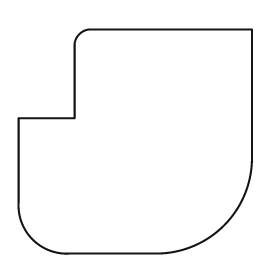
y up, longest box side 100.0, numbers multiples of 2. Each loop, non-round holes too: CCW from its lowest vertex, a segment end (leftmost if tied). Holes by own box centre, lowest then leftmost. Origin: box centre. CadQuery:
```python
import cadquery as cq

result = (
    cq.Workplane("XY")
    .moveTo(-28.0, -48.0)
    .lineTo(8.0, -48.0)
    .threePointArc((38.0, -36.0), (50.0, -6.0))
    .lineTo(50.0, 48.0)
    .lineTo(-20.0, 48.0)
    .threePointArc((-24.0, 46.0), (-26.0, 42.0))
    .lineTo(-26.0, 10.0)
    .lineTo(-50.0, 10.0)
    .lineTo(-50.0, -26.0)
    .threePointArc((-44.0, -42.0), (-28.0, -48.0))
    .close()
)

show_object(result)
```